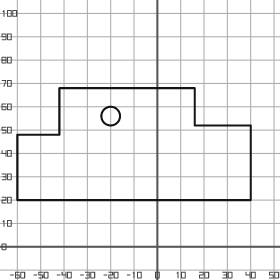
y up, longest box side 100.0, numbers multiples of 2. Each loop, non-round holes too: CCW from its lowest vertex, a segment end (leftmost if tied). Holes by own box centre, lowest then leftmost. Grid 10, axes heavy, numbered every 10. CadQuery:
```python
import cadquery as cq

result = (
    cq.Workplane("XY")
    .moveTo(-60.0, 20.0)
    .lineTo(40.0, 20.0)
    .lineTo(40.0, 52.0)
    .lineTo(16.0, 52.0)
    .lineTo(16.0, 68.0)
    .lineTo(-42.0, 68.0)
    .lineTo(-42.0, 48.0)
    .lineTo(-60.0, 48.0)
    .close()
    .moveTo(-20.0, 56.0)
    .circle(4.0)
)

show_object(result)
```